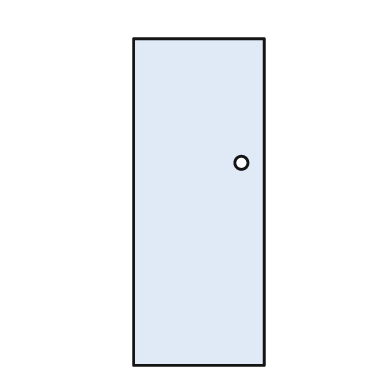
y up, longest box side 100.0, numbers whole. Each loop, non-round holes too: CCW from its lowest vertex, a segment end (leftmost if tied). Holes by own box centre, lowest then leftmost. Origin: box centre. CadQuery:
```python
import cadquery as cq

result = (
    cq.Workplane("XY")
    .moveTo(-20.0, -50.0)
    .lineTo(20.0, -50.0)
    .lineTo(20.0, 50.0)
    .lineTo(-20.0, 50.0)
    .close()
    .moveTo(13.0, 12.0)
    .circle(2.0)
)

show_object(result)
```